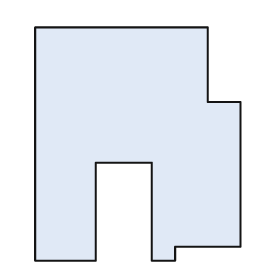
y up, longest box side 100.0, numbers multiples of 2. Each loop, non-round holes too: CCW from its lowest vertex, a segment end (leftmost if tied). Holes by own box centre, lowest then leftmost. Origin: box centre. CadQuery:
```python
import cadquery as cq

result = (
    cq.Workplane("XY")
    .moveTo(-44.0, -50.0)
    .lineTo(-18.0, -50.0)
    .lineTo(-18.0, -8.0)
    .lineTo(6.0, -8.0)
    .lineTo(6.0, -50.0)
    .lineTo(16.0, -50.0)
    .lineTo(16.0, -44.0)
    .lineTo(44.0, -44.0)
    .lineTo(44.0, 18.0)
    .lineTo(30.0, 18.0)
    .lineTo(30.0, 50.0)
    .lineTo(-44.0, 50.0)
    .close()
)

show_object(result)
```